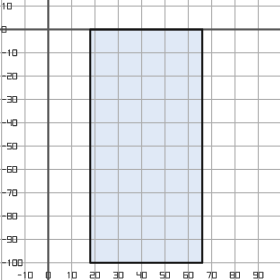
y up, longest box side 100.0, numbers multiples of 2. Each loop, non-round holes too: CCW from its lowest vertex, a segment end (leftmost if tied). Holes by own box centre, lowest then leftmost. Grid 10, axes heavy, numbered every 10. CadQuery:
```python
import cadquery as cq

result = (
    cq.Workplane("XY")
    .moveTo(18.0, -100.0)
    .lineTo(66.0, -100.0)
    .lineTo(66.0, 0.0)
    .lineTo(18.0, 0.0)
    .close()
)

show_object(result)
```